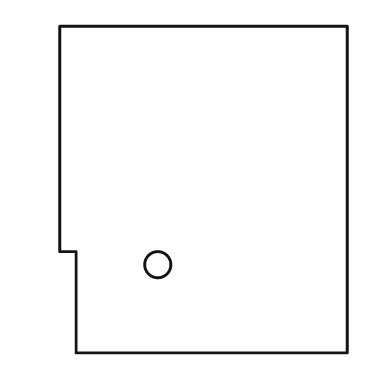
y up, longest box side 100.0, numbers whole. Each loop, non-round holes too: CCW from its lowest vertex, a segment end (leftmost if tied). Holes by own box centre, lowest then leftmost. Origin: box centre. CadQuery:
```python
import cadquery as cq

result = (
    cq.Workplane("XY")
    .moveTo(-39.0, -50.0)
    .lineTo(44.0, -50.0)
    .lineTo(44.0, 50.0)
    .lineTo(-44.0, 50.0)
    .lineTo(-44.0, -19.0)
    .lineTo(-39.0, -19.0)
    .close()
    .moveTo(-14.0, -23.0)
    .circle(4.0)
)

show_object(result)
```